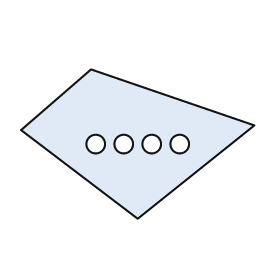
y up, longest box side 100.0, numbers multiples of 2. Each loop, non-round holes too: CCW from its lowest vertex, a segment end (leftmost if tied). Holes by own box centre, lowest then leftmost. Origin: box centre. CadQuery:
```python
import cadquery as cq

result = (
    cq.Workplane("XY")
    .moveTo(0.0, -32.0)
    .lineTo(50.0, 8.0)
    .lineTo(-20.0, 32.0)
    .lineTo(-50.0, 6.0)
    .close()
    .moveTo(-18.0, 0.0)
    .circle(4.0)
    .moveTo(-6.0, 0.0)
    .circle(4.0)
    .moveTo(6.0, 0.0)
    .circle(4.0)
    .moveTo(18.0, 0.0)
    .circle(4.0)
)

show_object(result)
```